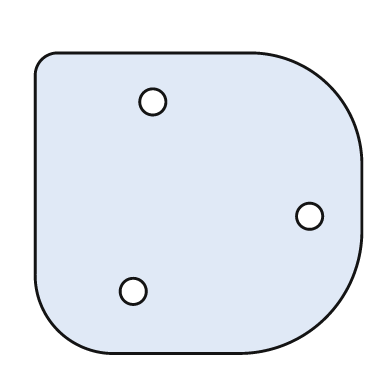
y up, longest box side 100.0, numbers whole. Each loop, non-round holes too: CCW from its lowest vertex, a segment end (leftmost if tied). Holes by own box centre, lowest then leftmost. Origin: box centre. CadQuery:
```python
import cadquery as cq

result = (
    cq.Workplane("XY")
    .moveTo(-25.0, -46.0)
    .lineTo(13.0, -46.0)
    .threePointArc((39.0, -35.0), (50.0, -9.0))
    .lineTo(50.0, 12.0)
    .threePointArc((40.0, 36.0), (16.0, 46.0))
    .lineTo(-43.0, 46.0)
    .threePointArc((-48.0, 44.0), (-50.0, 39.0))
    .lineTo(-50.0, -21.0)
    .threePointArc((-43.0, -39.0), (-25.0, -46.0))
    .close()
    .moveTo(-20.0, -27.0)
    .circle(4.0)
    .moveTo(34.0, -4.0)
    .circle(4.0)
    .moveTo(-14.0, 31.0)
    .circle(4.0)
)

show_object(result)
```